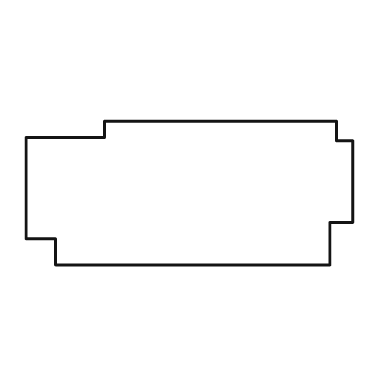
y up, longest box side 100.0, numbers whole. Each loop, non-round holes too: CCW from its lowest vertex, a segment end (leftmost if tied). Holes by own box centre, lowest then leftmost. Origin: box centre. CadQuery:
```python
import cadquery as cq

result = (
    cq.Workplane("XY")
    .moveTo(-41.0, -22.0)
    .lineTo(43.0, -22.0)
    .lineTo(43.0, -9.0)
    .lineTo(50.0, -9.0)
    .lineTo(50.0, 16.0)
    .lineTo(45.0, 16.0)
    .lineTo(45.0, 22.0)
    .lineTo(-26.0, 22.0)
    .lineTo(-26.0, 17.0)
    .lineTo(-50.0, 17.0)
    .lineTo(-50.0, -14.0)
    .lineTo(-41.0, -14.0)
    .close()
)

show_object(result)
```